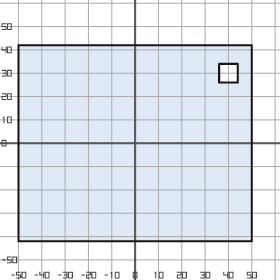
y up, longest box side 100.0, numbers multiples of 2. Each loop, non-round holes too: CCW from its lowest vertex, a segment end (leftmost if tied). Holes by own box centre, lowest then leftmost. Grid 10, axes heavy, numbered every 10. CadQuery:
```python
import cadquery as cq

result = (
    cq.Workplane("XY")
    .moveTo(-50.0, -42.0)
    .lineTo(50.0, -42.0)
    .lineTo(50.0, 42.0)
    .lineTo(-50.0, 42.0)
    .close()
    .moveTo(36.0, 26.0)
    .lineTo(44.0, 26.0)
    .lineTo(44.0, 34.0)
    .lineTo(36.0, 34.0)
    .close()
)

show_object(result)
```